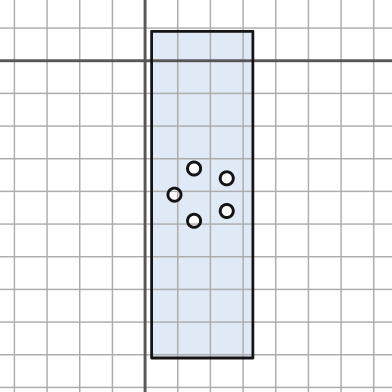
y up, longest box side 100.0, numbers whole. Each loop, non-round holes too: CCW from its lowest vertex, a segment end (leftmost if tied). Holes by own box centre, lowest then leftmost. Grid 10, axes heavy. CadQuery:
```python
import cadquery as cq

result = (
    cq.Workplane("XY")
    .moveTo(2.0, -91.0)
    .lineTo(33.0, -91.0)
    .lineTo(33.0, 9.0)
    .lineTo(2.0, 9.0)
    .close()
    .moveTo(15.0, -49.0)
    .circle(2.0)
    .moveTo(25.0, -46.0)
    .circle(2.0)
    .moveTo(9.0, -41.0)
    .circle(2.0)
    .moveTo(25.0, -36.0)
    .circle(2.0)
    .moveTo(15.0, -33.0)
    .circle(2.0)
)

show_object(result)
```